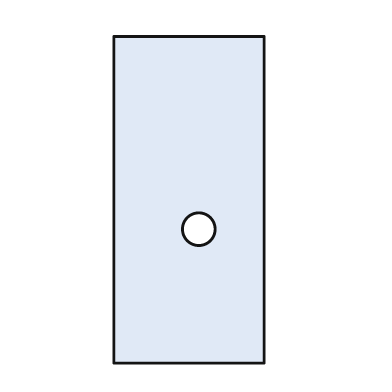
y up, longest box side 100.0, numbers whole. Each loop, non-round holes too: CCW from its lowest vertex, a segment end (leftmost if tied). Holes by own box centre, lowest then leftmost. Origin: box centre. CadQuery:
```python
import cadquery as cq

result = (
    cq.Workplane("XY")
    .moveTo(-23.0, -50.0)
    .lineTo(23.0, -50.0)
    .lineTo(23.0, 50.0)
    .lineTo(-23.0, 50.0)
    .close()
    .moveTo(3.0, -9.0)
    .circle(5.0)
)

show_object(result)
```